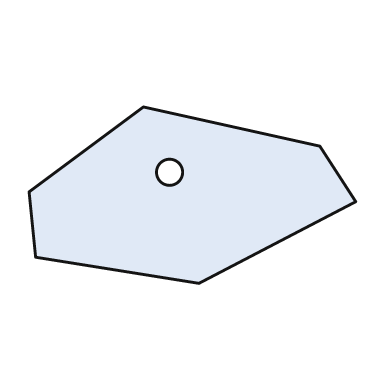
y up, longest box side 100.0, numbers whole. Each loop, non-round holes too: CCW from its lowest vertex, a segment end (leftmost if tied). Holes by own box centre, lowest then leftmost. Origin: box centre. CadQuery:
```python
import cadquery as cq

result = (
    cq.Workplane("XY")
    .moveTo(2.0, -27.0)
    .lineTo(50.0, -2.0)
    .lineTo(39.0, 15.0)
    .lineTo(-15.0, 27.0)
    .lineTo(-50.0, 1.0)
    .lineTo(-48.0, -19.0)
    .close()
    .moveTo(-7.0, 7.0)
    .circle(4.0)
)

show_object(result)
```